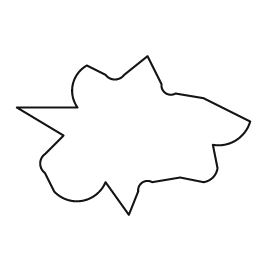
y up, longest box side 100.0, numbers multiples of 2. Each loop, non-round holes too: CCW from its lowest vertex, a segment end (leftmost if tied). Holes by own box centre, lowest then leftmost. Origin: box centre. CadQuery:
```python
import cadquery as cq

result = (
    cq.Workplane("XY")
    .moveTo(-2.0, -34.0)
    .lineTo(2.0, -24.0)
    .threePointArc((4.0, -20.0), (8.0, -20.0))
    .lineTo(20.0, -18.0)
    .lineTo(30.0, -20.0)
    .threePointArc((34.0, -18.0), (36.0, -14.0))
    .lineTo(34.0, -4.0)
    .threePointArc((44.0, -2.0), (50.0, 6.0))
    .lineTo(30.0, 16.0)
    .lineTo(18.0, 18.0)
    .threePointArc((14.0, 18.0), (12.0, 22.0))
    .lineTo(6.0, 34.0)
    .lineTo(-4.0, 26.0)
    .threePointArc((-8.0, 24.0), (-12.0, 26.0))
    .lineTo(-20.0, 30.0)
    .threePointArc((-26.0, 22.0), (-24.0, 12.0))
    .lineTo(-50.0, 12.0)
    .lineTo(-30.0, 0.0)
    .lineTo(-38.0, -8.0)
    .threePointArc((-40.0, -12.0), (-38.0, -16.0))
    .lineTo(-34.0, -24.0)
    .threePointArc((-22.0, -28.0), (-12.0, -20.0))
    .close()
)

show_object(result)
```